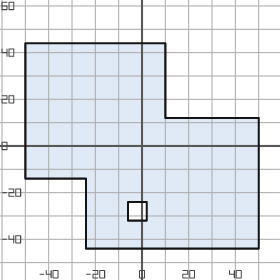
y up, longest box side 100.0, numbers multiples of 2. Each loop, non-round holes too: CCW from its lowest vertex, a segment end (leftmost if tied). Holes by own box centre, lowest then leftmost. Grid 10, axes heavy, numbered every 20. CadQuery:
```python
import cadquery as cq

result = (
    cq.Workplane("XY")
    .moveTo(-24.0, -44.0)
    .lineTo(50.0, -44.0)
    .lineTo(50.0, 12.0)
    .lineTo(10.0, 12.0)
    .lineTo(10.0, 44.0)
    .lineTo(-50.0, 44.0)
    .lineTo(-50.0, -14.0)
    .lineTo(-24.0, -14.0)
    .close()
    .moveTo(-6.0, -32.0)
    .lineTo(2.0, -32.0)
    .lineTo(2.0, -24.0)
    .lineTo(-6.0, -24.0)
    .close()
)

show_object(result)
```